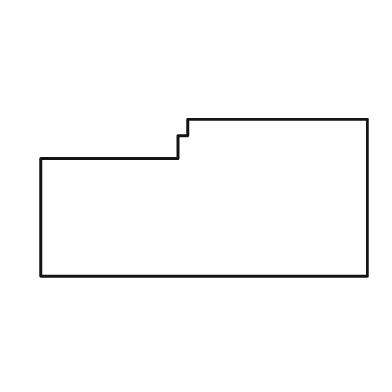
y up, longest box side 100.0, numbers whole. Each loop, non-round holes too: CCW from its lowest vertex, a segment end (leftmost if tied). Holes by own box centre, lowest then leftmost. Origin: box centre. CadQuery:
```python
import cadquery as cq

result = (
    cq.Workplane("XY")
    .moveTo(-50.0, -24.0)
    .lineTo(50.0, -24.0)
    .lineTo(50.0, 24.0)
    .lineTo(-5.0, 24.0)
    .lineTo(-5.0, 19.0)
    .lineTo(-8.0, 19.0)
    .lineTo(-8.0, 12.0)
    .lineTo(-50.0, 12.0)
    .close()
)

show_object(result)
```